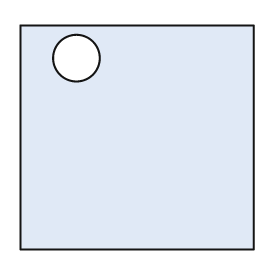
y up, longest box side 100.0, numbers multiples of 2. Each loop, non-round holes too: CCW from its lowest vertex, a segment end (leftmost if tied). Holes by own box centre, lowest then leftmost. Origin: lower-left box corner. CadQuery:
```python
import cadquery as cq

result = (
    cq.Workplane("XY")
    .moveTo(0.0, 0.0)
    .lineTo(100.0, 0.0)
    .lineTo(100.0, 96.0)
    .lineTo(0.0, 96.0)
    .close()
    .moveTo(24.0, 82.0)
    .circle(10.0)
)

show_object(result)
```